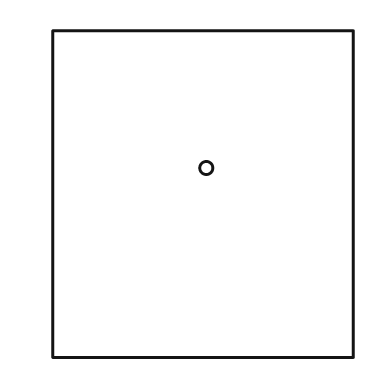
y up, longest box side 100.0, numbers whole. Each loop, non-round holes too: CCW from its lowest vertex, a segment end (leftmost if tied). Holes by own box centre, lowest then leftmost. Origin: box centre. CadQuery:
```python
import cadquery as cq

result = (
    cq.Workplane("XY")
    .moveTo(-46.0, -50.0)
    .lineTo(46.0, -50.0)
    .lineTo(46.0, 50.0)
    .lineTo(-46.0, 50.0)
    .close()
    .moveTo(1.0, 8.0)
    .circle(2.0)
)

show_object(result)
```